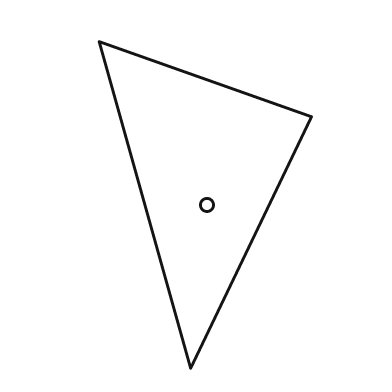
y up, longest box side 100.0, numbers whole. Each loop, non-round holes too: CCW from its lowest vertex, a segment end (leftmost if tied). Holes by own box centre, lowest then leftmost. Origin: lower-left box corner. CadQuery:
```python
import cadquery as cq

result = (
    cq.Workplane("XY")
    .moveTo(28.0, 0.0)
    .lineTo(65.0, 77.0)
    .lineTo(0.0, 100.0)
    .close()
    .moveTo(33.0, 50.0)
    .circle(2.0)
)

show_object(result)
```